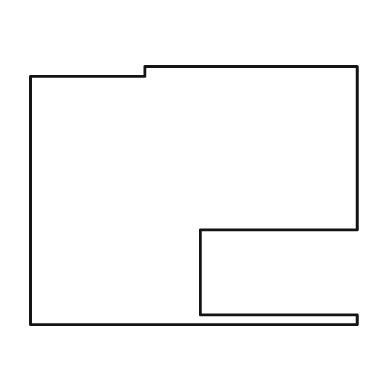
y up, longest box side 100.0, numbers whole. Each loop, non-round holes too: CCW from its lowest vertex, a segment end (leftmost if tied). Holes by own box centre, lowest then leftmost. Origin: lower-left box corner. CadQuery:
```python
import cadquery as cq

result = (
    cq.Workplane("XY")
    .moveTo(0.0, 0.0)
    .lineTo(100.0, 0.0)
    .lineTo(100.0, 3.0)
    .lineTo(52.0, 3.0)
    .lineTo(52.0, 29.0)
    .lineTo(100.0, 29.0)
    .lineTo(100.0, 79.0)
    .lineTo(35.0, 79.0)
    .lineTo(35.0, 76.0)
    .lineTo(0.0, 76.0)
    .close()
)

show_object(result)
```